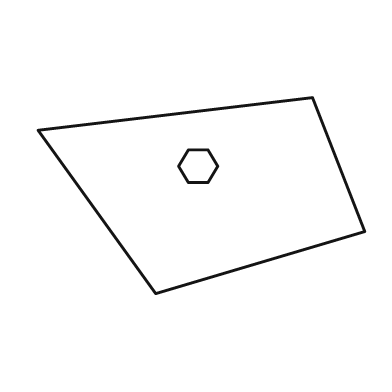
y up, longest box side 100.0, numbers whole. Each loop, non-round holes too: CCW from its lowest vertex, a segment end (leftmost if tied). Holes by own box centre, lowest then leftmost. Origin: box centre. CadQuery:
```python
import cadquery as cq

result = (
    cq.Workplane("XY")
    .moveTo(-14.0, -30.0)
    .lineTo(50.0, -11.0)
    .lineTo(34.0, 30.0)
    .lineTo(-50.0, 20.0)
    .close()
    .moveTo(-4.0, 4.0)
    .lineTo(2.0, 4.0)
    .lineTo(5.0, 9.0)
    .lineTo(2.0, 14.0)
    .lineTo(-4.0, 14.0)
    .lineTo(-7.0, 9.0)
    .close()
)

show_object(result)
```